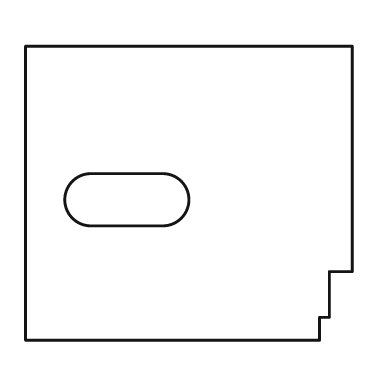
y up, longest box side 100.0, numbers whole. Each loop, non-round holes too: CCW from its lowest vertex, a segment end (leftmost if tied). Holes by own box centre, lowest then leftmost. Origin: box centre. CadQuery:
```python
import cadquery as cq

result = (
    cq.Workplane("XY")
    .moveTo(-50.0, -45.0)
    .lineTo(40.0, -45.0)
    .lineTo(40.0, -38.0)
    .lineTo(43.0, -38.0)
    .lineTo(43.0, -24.0)
    .lineTo(50.0, -24.0)
    .lineTo(50.0, 45.0)
    .lineTo(-50.0, 45.0)
    .close()
    .moveTo(-30.0, -10.0)
    .lineTo(-8.0, -10.0)
    .threePointArc((0.0, -2.0), (-8.0, 6.0))
    .lineTo(-30.0, 6.0)
    .threePointArc((-38.0, -2.0), (-30.0, -10.0))
    .close()
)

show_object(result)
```